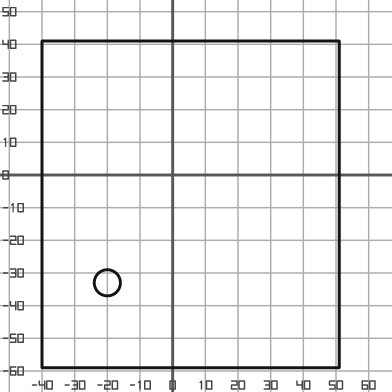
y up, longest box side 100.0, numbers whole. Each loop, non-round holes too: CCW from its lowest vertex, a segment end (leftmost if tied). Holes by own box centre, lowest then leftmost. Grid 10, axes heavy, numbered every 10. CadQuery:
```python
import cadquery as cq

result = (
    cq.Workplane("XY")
    .moveTo(-40.0, -59.0)
    .lineTo(51.0, -59.0)
    .lineTo(51.0, 41.0)
    .lineTo(-40.0, 41.0)
    .close()
    .moveTo(-20.0, -33.0)
    .circle(4.0)
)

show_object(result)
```